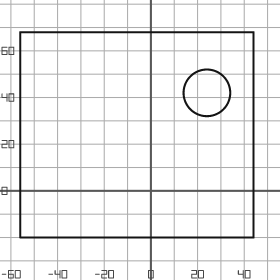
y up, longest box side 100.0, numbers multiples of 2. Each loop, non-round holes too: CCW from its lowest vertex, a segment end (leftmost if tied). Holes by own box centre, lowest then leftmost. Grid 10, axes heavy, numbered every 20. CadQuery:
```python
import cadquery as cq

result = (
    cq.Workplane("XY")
    .moveTo(-56.0, -20.0)
    .lineTo(44.0, -20.0)
    .lineTo(44.0, 68.0)
    .lineTo(-56.0, 68.0)
    .close()
    .moveTo(24.0, 42.0)
    .circle(10.0)
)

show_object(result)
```